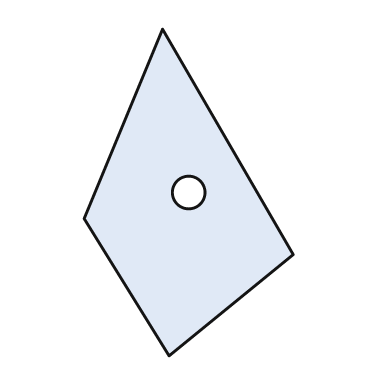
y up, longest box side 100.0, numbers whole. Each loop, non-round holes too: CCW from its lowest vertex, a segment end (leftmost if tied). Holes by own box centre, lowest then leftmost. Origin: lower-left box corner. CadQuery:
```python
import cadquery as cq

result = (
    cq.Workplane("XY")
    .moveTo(26.0, 0.0)
    .lineTo(64.0, 31.0)
    .lineTo(24.0, 100.0)
    .lineTo(0.0, 42.0)
    .close()
    .moveTo(32.0, 50.0)
    .circle(5.0)
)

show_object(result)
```